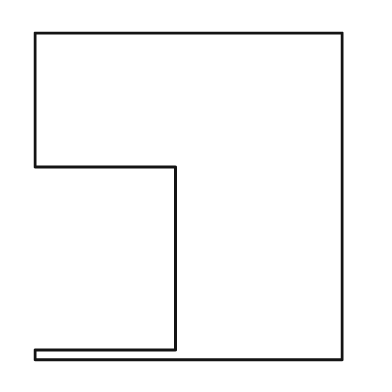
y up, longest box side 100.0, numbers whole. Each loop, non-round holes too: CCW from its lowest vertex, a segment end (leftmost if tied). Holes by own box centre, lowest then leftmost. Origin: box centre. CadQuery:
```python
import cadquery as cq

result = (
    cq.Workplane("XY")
    .moveTo(-47.0, -50.0)
    .lineTo(47.0, -50.0)
    .lineTo(47.0, 50.0)
    .lineTo(-47.0, 50.0)
    .lineTo(-47.0, 9.0)
    .lineTo(-4.0, 9.0)
    .lineTo(-4.0, -47.0)
    .lineTo(-47.0, -47.0)
    .close()
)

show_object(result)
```